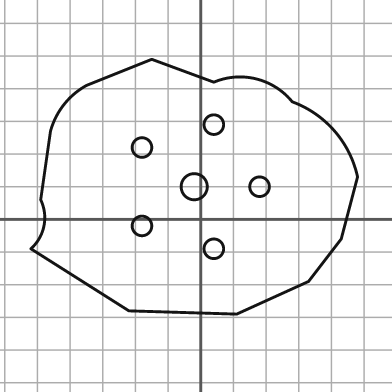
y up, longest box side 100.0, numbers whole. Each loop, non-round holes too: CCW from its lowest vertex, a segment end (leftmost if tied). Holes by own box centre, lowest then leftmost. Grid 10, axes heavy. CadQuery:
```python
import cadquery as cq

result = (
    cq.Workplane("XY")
    .moveTo(11.0, -29.0)
    .lineTo(33.0, -19.0)
    .lineTo(43.0, -6.0)
    .lineTo(48.0, 13.0)
    .threePointArc((41.0, 27.0), (28.0, 36.0))
    .threePointArc((17.0, 43.0), (4.0, 42.0))
    .lineTo(-15.0, 49.0)
    .lineTo(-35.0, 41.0)
    .threePointArc((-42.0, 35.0), (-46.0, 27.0))
    .lineTo(-49.0, 6.0)
    .threePointArc((-48.0, -2.0), (-52.0, -9.0))
    .lineTo(-22.0, -28.0)
    .close()
    .moveTo(4.0, -9.0)
    .circle(3.0)
    .moveTo(-18.0, -2.0)
    .circle(3.0)
    .moveTo(-2.0, 10.0)
    .circle(4.0)
    .moveTo(18.0, 10.0)
    .circle(3.0)
    .moveTo(-18.0, 22.0)
    .circle(3.0)
    .moveTo(4.0, 29.0)
    .circle(3.0)
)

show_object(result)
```